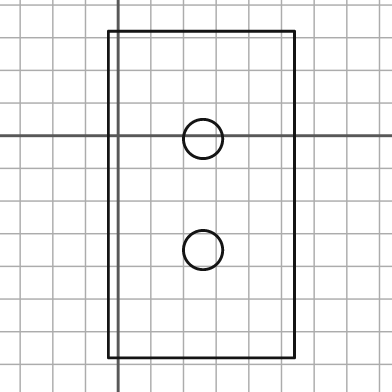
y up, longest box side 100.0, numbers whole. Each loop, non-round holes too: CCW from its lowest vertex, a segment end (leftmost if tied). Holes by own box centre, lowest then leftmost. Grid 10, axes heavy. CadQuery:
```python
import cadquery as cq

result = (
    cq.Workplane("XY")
    .moveTo(-3.0, -68.0)
    .lineTo(54.0, -68.0)
    .lineTo(54.0, 32.0)
    .lineTo(-3.0, 32.0)
    .close()
    .moveTo(26.0, -35.0)
    .circle(6.0)
    .moveTo(26.0, -1.0)
    .circle(6.0)
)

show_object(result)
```